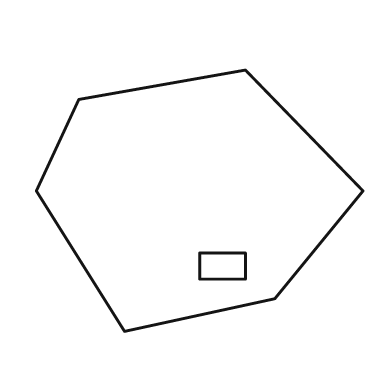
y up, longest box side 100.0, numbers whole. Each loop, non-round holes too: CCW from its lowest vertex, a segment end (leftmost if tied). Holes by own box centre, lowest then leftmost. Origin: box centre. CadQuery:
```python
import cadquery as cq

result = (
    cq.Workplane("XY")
    .moveTo(-23.0, -40.0)
    .lineTo(23.0, -30.0)
    .lineTo(50.0, 3.0)
    .lineTo(14.0, 40.0)
    .lineTo(-37.0, 31.0)
    .lineTo(-50.0, 3.0)
    .close()
    .moveTo(0.0, -24.0)
    .lineTo(14.0, -24.0)
    .lineTo(14.0, -16.0)
    .lineTo(0.0, -16.0)
    .close()
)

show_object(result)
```